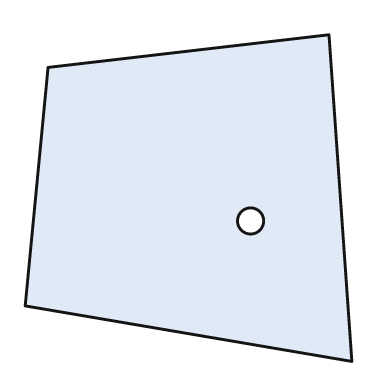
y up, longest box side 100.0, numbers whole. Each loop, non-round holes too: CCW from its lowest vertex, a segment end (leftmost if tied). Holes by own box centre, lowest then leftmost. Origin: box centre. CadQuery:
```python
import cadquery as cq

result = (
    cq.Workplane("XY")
    .moveTo(50.0, -50.0)
    .lineTo(43.0, 50.0)
    .lineTo(-43.0, 40.0)
    .lineTo(-50.0, -33.0)
    .close()
    .moveTo(19.0, -7.0)
    .circle(4.0)
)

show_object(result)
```